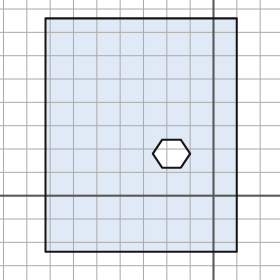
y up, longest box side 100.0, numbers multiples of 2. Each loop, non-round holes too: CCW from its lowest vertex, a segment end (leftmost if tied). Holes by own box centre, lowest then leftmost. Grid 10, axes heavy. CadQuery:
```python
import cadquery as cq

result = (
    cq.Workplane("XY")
    .moveTo(-72.0, -24.0)
    .lineTo(10.0, -24.0)
    .lineTo(10.0, 76.0)
    .lineTo(-72.0, 76.0)
    .close()
    .moveTo(-22.0, 12.0)
    .lineTo(-14.0, 12.0)
    .lineTo(-10.0, 18.0)
    .lineTo(-14.0, 24.0)
    .lineTo(-22.0, 24.0)
    .lineTo(-26.0, 18.0)
    .close()
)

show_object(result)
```